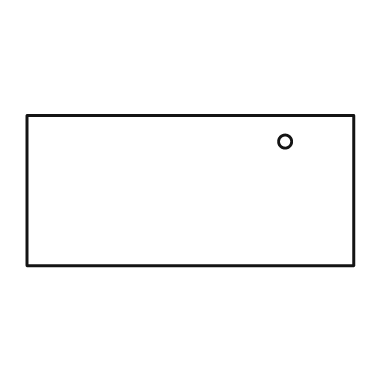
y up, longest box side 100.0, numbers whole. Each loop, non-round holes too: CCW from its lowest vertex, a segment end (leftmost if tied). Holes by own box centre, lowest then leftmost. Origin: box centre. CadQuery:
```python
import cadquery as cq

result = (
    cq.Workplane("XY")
    .moveTo(-50.0, -23.0)
    .lineTo(50.0, -23.0)
    .lineTo(50.0, 23.0)
    .lineTo(-50.0, 23.0)
    .close()
    .moveTo(29.0, 15.0)
    .circle(2.0)
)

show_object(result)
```